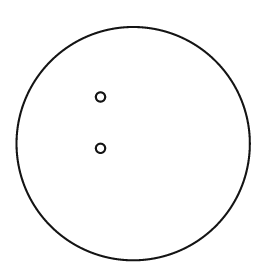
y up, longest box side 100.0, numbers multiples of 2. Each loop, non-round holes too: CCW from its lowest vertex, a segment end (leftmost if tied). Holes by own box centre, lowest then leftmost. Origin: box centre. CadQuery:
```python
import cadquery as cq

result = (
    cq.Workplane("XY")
    .moveTo(0.0, 0.0)
    .circle(50.0)
    .moveTo(-14.0, -2.0)
    .circle(2.0)
    .moveTo(-14.0, 20.0)
    .circle(2.0)
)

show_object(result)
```